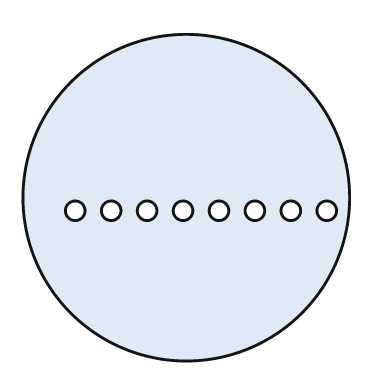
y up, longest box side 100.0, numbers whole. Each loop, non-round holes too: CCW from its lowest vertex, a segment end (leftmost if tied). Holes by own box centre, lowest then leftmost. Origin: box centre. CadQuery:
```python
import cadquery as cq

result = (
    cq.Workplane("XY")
    .moveTo(0.0, 0.0)
    .circle(50.0)
    .moveTo(-34.0, -4.0)
    .circle(3.0)
    .moveTo(-23.0, -4.0)
    .circle(3.0)
    .moveTo(-12.0, -4.0)
    .circle(3.0)
    .moveTo(-1.0, -4.0)
    .circle(3.0)
    .moveTo(10.0, -4.0)
    .circle(3.0)
    .moveTo(21.0, -4.0)
    .circle(3.0)
    .moveTo(32.0, -4.0)
    .circle(3.0)
    .moveTo(43.0, -4.0)
    .circle(3.0)
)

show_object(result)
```